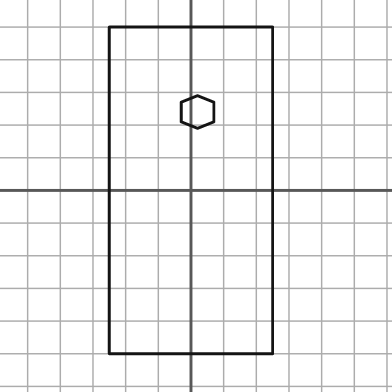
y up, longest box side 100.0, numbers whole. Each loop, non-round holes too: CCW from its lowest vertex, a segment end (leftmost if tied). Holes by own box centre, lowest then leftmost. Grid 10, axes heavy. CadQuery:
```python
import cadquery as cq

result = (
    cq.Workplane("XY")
    .moveTo(-25.0, -50.0)
    .lineTo(25.0, -50.0)
    .lineTo(25.0, 50.0)
    .lineTo(-25.0, 50.0)
    .close()
    .moveTo(2.0, 19.0)
    .lineTo(7.0, 21.0)
    .lineTo(7.0, 27.0)
    .lineTo(2.0, 29.0)
    .lineTo(-3.0, 27.0)
    .lineTo(-3.0, 21.0)
    .close()
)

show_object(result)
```